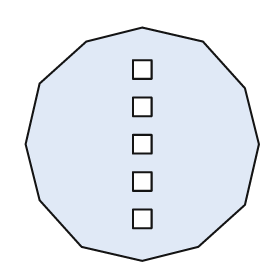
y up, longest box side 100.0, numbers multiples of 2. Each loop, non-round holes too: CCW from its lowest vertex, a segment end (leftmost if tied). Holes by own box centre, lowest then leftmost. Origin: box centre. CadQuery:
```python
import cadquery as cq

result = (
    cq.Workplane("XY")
    .moveTo(0.0, -50.0)
    .lineTo(24.0, -44.0)
    .lineTo(44.0, -26.0)
    .lineTo(50.0, 0.0)
    .lineTo(44.0, 24.0)
    .lineTo(26.0, 44.0)
    .lineTo(0.0, 50.0)
    .lineTo(-24.0, 44.0)
    .lineTo(-44.0, 26.0)
    .lineTo(-50.0, 0.0)
    .lineTo(-44.0, -24.0)
    .lineTo(-26.0, -44.0)
    .close()
    .moveTo(-4.0, -36.0)
    .lineTo(4.0, -36.0)
    .lineTo(4.0, -28.0)
    .lineTo(-4.0, -28.0)
    .close()
    .moveTo(-4.0, -20.0)
    .lineTo(4.0, -20.0)
    .lineTo(4.0, -12.0)
    .lineTo(-4.0, -12.0)
    .close()
    .moveTo(-4.0, -4.0)
    .lineTo(4.0, -4.0)
    .lineTo(4.0, 4.0)
    .lineTo(-4.0, 4.0)
    .close()
    .moveTo(-4.0, 12.0)
    .lineTo(4.0, 12.0)
    .lineTo(4.0, 20.0)
    .lineTo(-4.0, 20.0)
    .close()
    .moveTo(-4.0, 28.0)
    .lineTo(4.0, 28.0)
    .lineTo(4.0, 36.0)
    .lineTo(-4.0, 36.0)
    .close()
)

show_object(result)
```